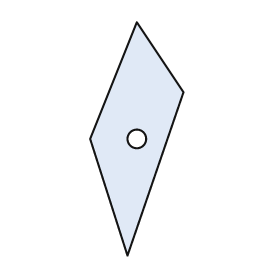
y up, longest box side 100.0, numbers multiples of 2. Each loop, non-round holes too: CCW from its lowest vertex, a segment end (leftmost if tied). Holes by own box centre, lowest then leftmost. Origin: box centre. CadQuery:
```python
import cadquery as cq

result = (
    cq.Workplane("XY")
    .moveTo(-4.0, -50.0)
    .lineTo(20.0, 20.0)
    .lineTo(0.0, 50.0)
    .lineTo(-20.0, 0.0)
    .close()
    .moveTo(0.0, 0.0)
    .circle(4.0)
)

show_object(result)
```